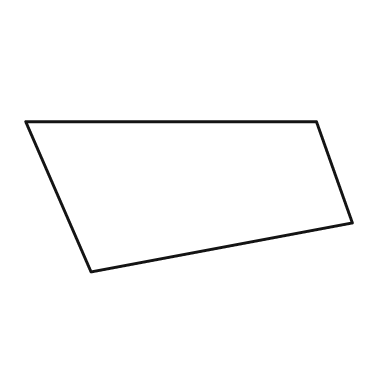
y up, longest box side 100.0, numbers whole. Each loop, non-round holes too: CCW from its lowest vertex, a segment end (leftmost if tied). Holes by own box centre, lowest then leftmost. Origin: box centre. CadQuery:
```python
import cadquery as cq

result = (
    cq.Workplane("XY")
    .moveTo(-30.0, -23.0)
    .lineTo(50.0, -8.0)
    .lineTo(39.0, 23.0)
    .lineTo(-50.0, 23.0)
    .close()
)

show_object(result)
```